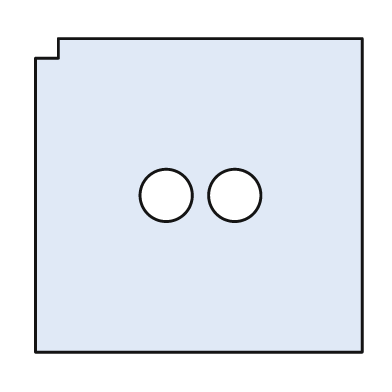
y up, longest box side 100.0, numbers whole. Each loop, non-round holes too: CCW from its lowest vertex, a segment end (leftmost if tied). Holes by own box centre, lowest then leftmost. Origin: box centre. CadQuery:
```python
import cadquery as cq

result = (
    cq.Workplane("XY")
    .moveTo(-50.0, -48.0)
    .lineTo(50.0, -48.0)
    .lineTo(50.0, 48.0)
    .lineTo(-43.0, 48.0)
    .lineTo(-43.0, 42.0)
    .lineTo(-50.0, 42.0)
    .close()
    .moveTo(-10.0, 0.0)
    .circle(8.0)
    .moveTo(11.0, 0.0)
    .circle(8.0)
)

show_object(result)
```